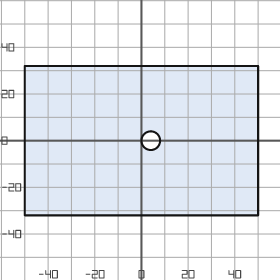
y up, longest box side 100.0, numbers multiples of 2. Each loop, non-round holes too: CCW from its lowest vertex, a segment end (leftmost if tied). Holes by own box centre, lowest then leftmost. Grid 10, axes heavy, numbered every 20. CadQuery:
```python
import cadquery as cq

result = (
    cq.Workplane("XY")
    .moveTo(-50.0, -32.0)
    .lineTo(50.0, -32.0)
    .lineTo(50.0, 32.0)
    .lineTo(-50.0, 32.0)
    .close()
    .moveTo(4.0, 0.0)
    .circle(4.0)
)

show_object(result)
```